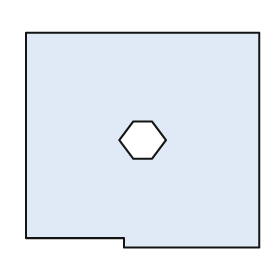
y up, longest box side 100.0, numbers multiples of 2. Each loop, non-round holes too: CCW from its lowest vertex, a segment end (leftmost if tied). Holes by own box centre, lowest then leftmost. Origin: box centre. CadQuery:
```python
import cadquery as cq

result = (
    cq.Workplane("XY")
    .moveTo(-8.0, -46.0)
    .lineTo(50.0, -46.0)
    .lineTo(50.0, 46.0)
    .lineTo(-50.0, 46.0)
    .lineTo(-50.0, -42.0)
    .lineTo(-8.0, -42.0)
    .close()
    .moveTo(-4.0, -8.0)
    .lineTo(4.0, -8.0)
    .lineTo(10.0, 0.0)
    .lineTo(4.0, 8.0)
    .lineTo(-4.0, 8.0)
    .lineTo(-10.0, 0.0)
    .close()
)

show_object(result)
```